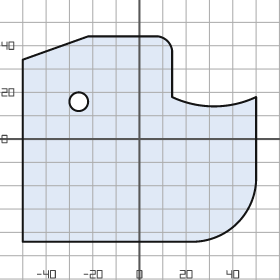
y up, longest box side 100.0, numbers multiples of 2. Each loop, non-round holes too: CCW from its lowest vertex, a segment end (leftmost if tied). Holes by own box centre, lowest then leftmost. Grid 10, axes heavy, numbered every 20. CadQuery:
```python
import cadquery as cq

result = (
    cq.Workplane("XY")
    .moveTo(-50.0, -44.0)
    .lineTo(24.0, -44.0)
    .threePointArc((42.0, -36.0), (50.0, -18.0))
    .lineTo(50.0, 18.0)
    .threePointArc((32.0, 14.0), (14.0, 18.0))
    .lineTo(14.0, 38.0)
    .threePointArc((12.0, 42.0), (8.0, 44.0))
    .lineTo(-22.0, 44.0)
    .lineTo(-50.0, 34.0)
    .close()
    .moveTo(-26.0, 16.0)
    .circle(4.0)
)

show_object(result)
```